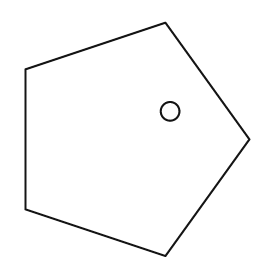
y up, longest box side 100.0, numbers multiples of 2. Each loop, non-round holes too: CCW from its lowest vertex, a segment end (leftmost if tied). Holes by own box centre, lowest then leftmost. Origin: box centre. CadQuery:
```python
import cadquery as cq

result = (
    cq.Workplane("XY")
    .moveTo(12.0, -50.0)
    .lineTo(48.0, 0.0)
    .lineTo(12.0, 50.0)
    .lineTo(-48.0, 30.0)
    .lineTo(-48.0, -30.0)
    .close()
    .moveTo(14.0, 12.0)
    .circle(4.0)
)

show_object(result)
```